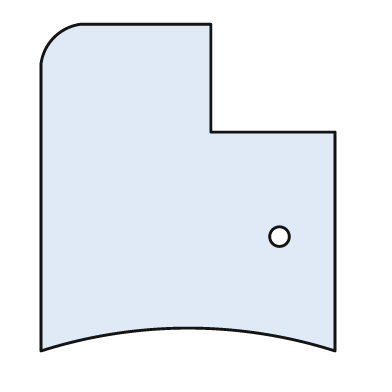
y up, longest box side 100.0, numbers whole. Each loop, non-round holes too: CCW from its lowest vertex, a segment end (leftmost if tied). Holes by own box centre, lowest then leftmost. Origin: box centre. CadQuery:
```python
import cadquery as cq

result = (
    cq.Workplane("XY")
    .moveTo(-45.0, -50.0)
    .threePointArc((0.0, -43.0), (45.0, -50.0))
    .lineTo(45.0, 17.0)
    .lineTo(7.0, 17.0)
    .lineTo(7.0, 50.0)
    .lineTo(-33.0, 50.0)
    .threePointArc((-41.0, 46.0), (-45.0, 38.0))
    .close()
    .moveTo(28.0, -15.0)
    .circle(3.0)
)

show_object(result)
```